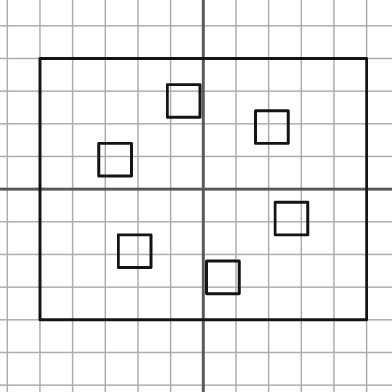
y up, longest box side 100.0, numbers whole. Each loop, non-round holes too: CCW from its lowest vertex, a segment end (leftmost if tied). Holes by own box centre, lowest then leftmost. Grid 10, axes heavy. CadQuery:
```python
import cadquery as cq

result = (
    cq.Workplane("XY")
    .moveTo(-50.0, -40.0)
    .lineTo(50.0, -40.0)
    .lineTo(50.0, 40.0)
    .lineTo(-50.0, 40.0)
    .close()
    .moveTo(1.0, -32.0)
    .lineTo(11.0, -32.0)
    .lineTo(11.0, -22.0)
    .lineTo(1.0, -22.0)
    .close()
    .moveTo(-26.0, -24.0)
    .lineTo(-16.0, -24.0)
    .lineTo(-16.0, -14.0)
    .lineTo(-26.0, -14.0)
    .close()
    .moveTo(22.0, -14.0)
    .lineTo(32.0, -14.0)
    .lineTo(32.0, -4.0)
    .lineTo(22.0, -4.0)
    .close()
    .moveTo(-32.0, 4.0)
    .lineTo(-22.0, 4.0)
    .lineTo(-22.0, 14.0)
    .lineTo(-32.0, 14.0)
    .close()
    .moveTo(16.0, 14.0)
    .lineTo(26.0, 14.0)
    .lineTo(26.0, 24.0)
    .lineTo(16.0, 24.0)
    .close()
    .moveTo(-11.0, 22.0)
    .lineTo(-1.0, 22.0)
    .lineTo(-1.0, 32.0)
    .lineTo(-11.0, 32.0)
    .close()
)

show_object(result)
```